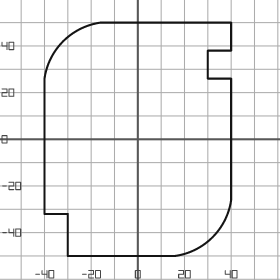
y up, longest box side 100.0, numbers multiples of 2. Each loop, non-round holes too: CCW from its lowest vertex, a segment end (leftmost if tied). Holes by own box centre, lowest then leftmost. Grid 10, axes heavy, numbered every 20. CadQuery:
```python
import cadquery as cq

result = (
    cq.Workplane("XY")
    .moveTo(-30.0, -50.0)
    .lineTo(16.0, -50.0)
    .threePointArc((32.0, -42.0), (40.0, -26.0))
    .lineTo(40.0, 26.0)
    .lineTo(30.0, 26.0)
    .lineTo(30.0, 38.0)
    .lineTo(40.0, 38.0)
    .lineTo(40.0, 50.0)
    .lineTo(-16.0, 50.0)
    .threePointArc((-32.0, 42.0), (-40.0, 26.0))
    .lineTo(-40.0, -32.0)
    .lineTo(-30.0, -32.0)
    .close()
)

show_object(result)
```